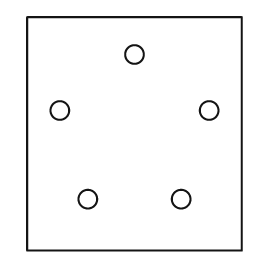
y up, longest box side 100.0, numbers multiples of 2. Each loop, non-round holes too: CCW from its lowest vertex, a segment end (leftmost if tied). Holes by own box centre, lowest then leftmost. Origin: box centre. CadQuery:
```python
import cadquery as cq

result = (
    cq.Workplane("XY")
    .moveTo(-46.0, -50.0)
    .lineTo(46.0, -50.0)
    .lineTo(46.0, 50.0)
    .lineTo(-46.0, 50.0)
    .close()
    .moveTo(-20.0, -28.0)
    .circle(4.0)
    .moveTo(20.0, -28.0)
    .circle(4.0)
    .moveTo(-32.0, 10.0)
    .circle(4.0)
    .moveTo(32.0, 10.0)
    .circle(4.0)
    .moveTo(0.0, 34.0)
    .circle(4.0)
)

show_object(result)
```